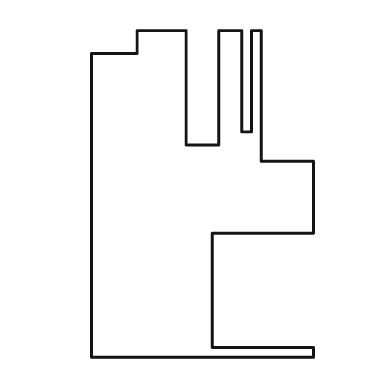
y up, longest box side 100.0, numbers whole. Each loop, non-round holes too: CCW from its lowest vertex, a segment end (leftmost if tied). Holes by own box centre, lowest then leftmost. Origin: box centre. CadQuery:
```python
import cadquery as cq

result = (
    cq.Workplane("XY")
    .moveTo(-34.0, -50.0)
    .lineTo(34.0, -50.0)
    .lineTo(34.0, -47.0)
    .lineTo(3.0, -47.0)
    .lineTo(3.0, -12.0)
    .lineTo(34.0, -12.0)
    .lineTo(34.0, 10.0)
    .lineTo(18.0, 10.0)
    .lineTo(18.0, 50.0)
    .lineTo(15.0, 50.0)
    .lineTo(15.0, 19.0)
    .lineTo(12.0, 19.0)
    .lineTo(12.0, 50.0)
    .lineTo(5.0, 50.0)
    .lineTo(5.0, 15.0)
    .lineTo(-5.0, 15.0)
    .lineTo(-5.0, 50.0)
    .lineTo(-20.0, 50.0)
    .lineTo(-20.0, 43.0)
    .lineTo(-34.0, 43.0)
    .close()
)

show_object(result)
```